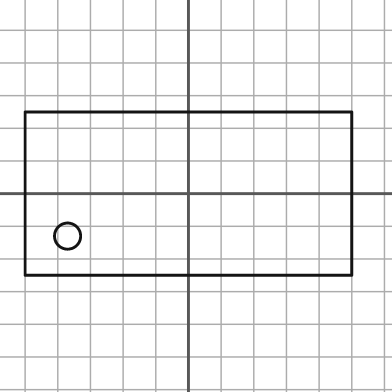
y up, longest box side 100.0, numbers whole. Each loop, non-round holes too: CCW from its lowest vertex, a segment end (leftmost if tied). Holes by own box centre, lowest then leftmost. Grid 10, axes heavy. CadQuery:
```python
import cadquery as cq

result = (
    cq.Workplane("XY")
    .moveTo(-50.0, -25.0)
    .lineTo(50.0, -25.0)
    .lineTo(50.0, 25.0)
    .lineTo(-50.0, 25.0)
    .close()
    .moveTo(-37.0, -13.0)
    .circle(4.0)
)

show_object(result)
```